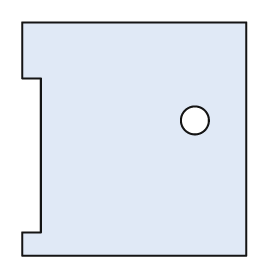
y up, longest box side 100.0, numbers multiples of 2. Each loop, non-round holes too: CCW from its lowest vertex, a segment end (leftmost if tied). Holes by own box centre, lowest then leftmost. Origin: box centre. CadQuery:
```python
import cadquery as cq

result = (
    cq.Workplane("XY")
    .moveTo(-48.0, -50.0)
    .lineTo(48.0, -50.0)
    .lineTo(48.0, 50.0)
    .lineTo(-48.0, 50.0)
    .lineTo(-48.0, 26.0)
    .lineTo(-40.0, 26.0)
    .lineTo(-40.0, -40.0)
    .lineTo(-48.0, -40.0)
    .close()
    .moveTo(26.0, 8.0)
    .circle(6.0)
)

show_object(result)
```